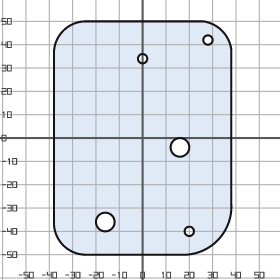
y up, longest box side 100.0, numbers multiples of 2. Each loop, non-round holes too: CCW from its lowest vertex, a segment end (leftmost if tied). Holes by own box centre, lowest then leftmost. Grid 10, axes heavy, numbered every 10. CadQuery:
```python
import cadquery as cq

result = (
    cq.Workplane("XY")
    .moveTo(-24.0, -50.0)
    .lineTo(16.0, -50.0)
    .threePointArc((32.0, -44.0), (38.0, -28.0))
    .lineTo(38.0, 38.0)
    .threePointArc((34.0, 46.0), (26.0, 50.0))
    .lineTo(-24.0, 50.0)
    .threePointArc((-34.0, 46.0), (-38.0, 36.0))
    .lineTo(-38.0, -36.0)
    .threePointArc((-34.0, -46.0), (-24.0, -50.0))
    .close()
    .moveTo(20.0, -40.0)
    .circle(2.0)
    .moveTo(-16.0, -36.0)
    .circle(4.0)
    .moveTo(16.0, -4.0)
    .circle(4.0)
    .moveTo(0.0, 34.0)
    .circle(2.0)
    .moveTo(28.0, 42.0)
    .circle(2.0)
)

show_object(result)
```